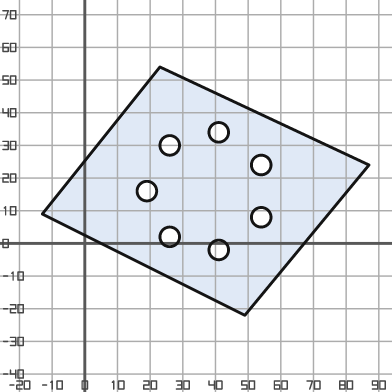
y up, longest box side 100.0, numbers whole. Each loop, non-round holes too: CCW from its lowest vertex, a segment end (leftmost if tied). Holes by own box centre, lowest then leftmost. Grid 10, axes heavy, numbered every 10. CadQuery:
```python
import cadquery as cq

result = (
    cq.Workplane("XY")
    .moveTo(49.0, -22.0)
    .lineTo(87.0, 24.0)
    .lineTo(23.0, 54.0)
    .lineTo(-13.0, 9.0)
    .close()
    .moveTo(41.0, -2.0)
    .circle(3.0)
    .moveTo(26.0, 2.0)
    .circle(3.0)
    .moveTo(54.0, 8.0)
    .circle(3.0)
    .moveTo(19.0, 16.0)
    .circle(3.0)
    .moveTo(54.0, 24.0)
    .circle(3.0)
    .moveTo(26.0, 30.0)
    .circle(3.0)
    .moveTo(41.0, 34.0)
    .circle(3.0)
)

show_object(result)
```